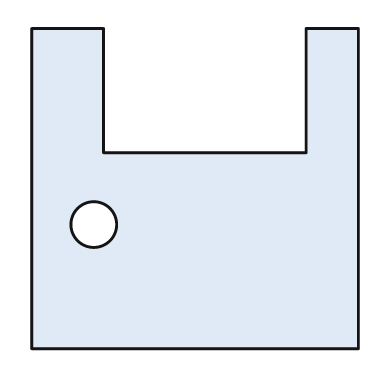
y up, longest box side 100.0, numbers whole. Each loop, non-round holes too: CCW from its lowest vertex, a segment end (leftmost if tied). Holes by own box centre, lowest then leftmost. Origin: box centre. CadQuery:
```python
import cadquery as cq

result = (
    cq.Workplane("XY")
    .moveTo(-50.0, -49.0)
    .lineTo(50.0, -49.0)
    .lineTo(50.0, 49.0)
    .lineTo(34.0, 49.0)
    .lineTo(34.0, 11.0)
    .lineTo(-28.0, 11.0)
    .lineTo(-28.0, 49.0)
    .lineTo(-50.0, 49.0)
    .close()
    .moveTo(-31.0, -11.0)
    .circle(7.0)
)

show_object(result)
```